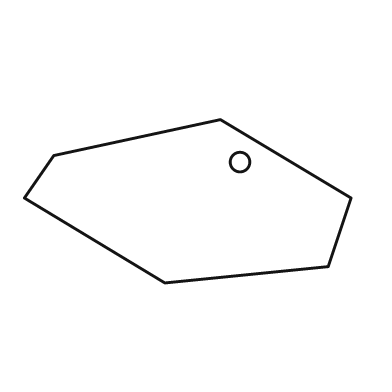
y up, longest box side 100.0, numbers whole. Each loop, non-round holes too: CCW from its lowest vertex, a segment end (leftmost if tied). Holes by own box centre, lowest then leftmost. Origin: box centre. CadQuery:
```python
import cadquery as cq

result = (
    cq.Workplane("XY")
    .moveTo(-7.0, -25.0)
    .lineTo(43.0, -20.0)
    .lineTo(50.0, 1.0)
    .lineTo(10.0, 25.0)
    .lineTo(-41.0, 14.0)
    .lineTo(-50.0, 1.0)
    .close()
    .moveTo(16.0, 12.0)
    .circle(3.0)
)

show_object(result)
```